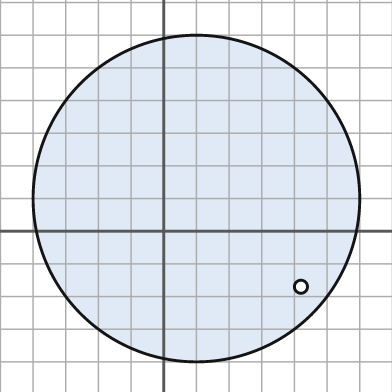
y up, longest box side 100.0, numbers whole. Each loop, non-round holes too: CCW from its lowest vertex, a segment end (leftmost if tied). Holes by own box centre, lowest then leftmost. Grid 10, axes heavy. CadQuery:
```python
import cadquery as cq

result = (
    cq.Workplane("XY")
    .moveTo(10.0, 10.0)
    .circle(50.0)
    .moveTo(42.0, -17.0)
    .circle(2.0)
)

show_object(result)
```